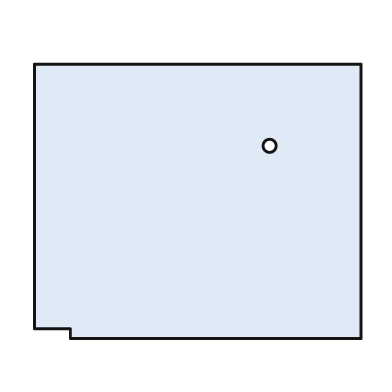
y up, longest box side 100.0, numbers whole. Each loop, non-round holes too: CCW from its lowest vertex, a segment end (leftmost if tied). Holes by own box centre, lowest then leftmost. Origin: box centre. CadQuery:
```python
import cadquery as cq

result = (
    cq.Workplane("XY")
    .moveTo(-39.0, -42.0)
    .lineTo(50.0, -42.0)
    .lineTo(50.0, 42.0)
    .lineTo(-50.0, 42.0)
    .lineTo(-50.0, -39.0)
    .lineTo(-39.0, -39.0)
    .close()
    .moveTo(22.0, 17.0)
    .circle(2.0)
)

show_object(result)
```